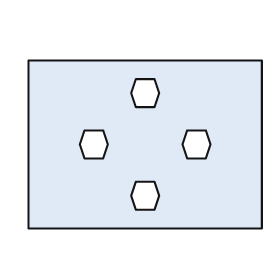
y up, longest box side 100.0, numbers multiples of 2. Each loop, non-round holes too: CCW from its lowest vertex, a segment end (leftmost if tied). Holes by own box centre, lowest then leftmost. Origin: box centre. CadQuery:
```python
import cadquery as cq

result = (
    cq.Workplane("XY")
    .moveTo(-50.0, -36.0)
    .lineTo(50.0, -36.0)
    .lineTo(50.0, 36.0)
    .lineTo(-50.0, 36.0)
    .close()
    .moveTo(-4.0, -28.0)
    .lineTo(4.0, -28.0)
    .lineTo(6.0, -22.0)
    .lineTo(4.0, -16.0)
    .lineTo(-4.0, -16.0)
    .lineTo(-6.0, -22.0)
    .close()
    .moveTo(-26.0, -6.0)
    .lineTo(-18.0, -6.0)
    .lineTo(-16.0, 0.0)
    .lineTo(-18.0, 6.0)
    .lineTo(-26.0, 6.0)
    .lineTo(-28.0, 0.0)
    .close()
    .moveTo(18.0, -6.0)
    .lineTo(26.0, -6.0)
    .lineTo(28.0, 0.0)
    .lineTo(26.0, 6.0)
    .lineTo(18.0, 6.0)
    .lineTo(16.0, 0.0)
    .close()
    .moveTo(-4.0, 16.0)
    .lineTo(4.0, 16.0)
    .lineTo(6.0, 22.0)
    .lineTo(4.0, 28.0)
    .lineTo(-4.0, 28.0)
    .lineTo(-6.0, 22.0)
    .close()
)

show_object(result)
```